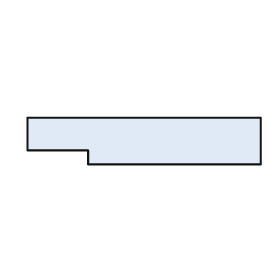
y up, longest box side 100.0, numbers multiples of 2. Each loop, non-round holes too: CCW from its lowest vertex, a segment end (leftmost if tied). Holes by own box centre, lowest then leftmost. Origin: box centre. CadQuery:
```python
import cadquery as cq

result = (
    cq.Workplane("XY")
    .moveTo(-24.0, -10.0)
    .lineTo(50.0, -10.0)
    .lineTo(50.0, 10.0)
    .lineTo(-50.0, 10.0)
    .lineTo(-50.0, -4.0)
    .lineTo(-24.0, -4.0)
    .close()
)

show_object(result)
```